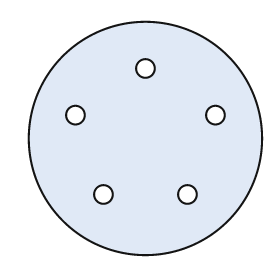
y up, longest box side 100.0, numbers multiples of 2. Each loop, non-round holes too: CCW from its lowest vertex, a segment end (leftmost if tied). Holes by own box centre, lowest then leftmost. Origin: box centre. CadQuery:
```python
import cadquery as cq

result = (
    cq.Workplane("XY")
    .moveTo(0.0, 0.0)
    .circle(50.0)
    .moveTo(-18.0, -24.0)
    .circle(4.0)
    .moveTo(18.0, -24.0)
    .circle(4.0)
    .moveTo(-30.0, 10.0)
    .circle(4.0)
    .moveTo(30.0, 10.0)
    .circle(4.0)
    .moveTo(0.0, 30.0)
    .circle(4.0)
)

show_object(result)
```